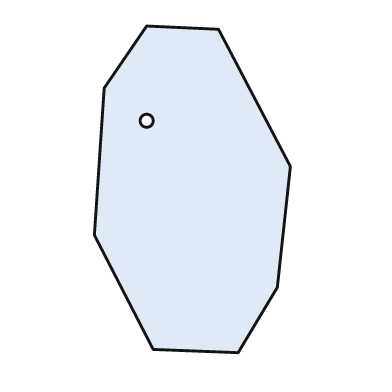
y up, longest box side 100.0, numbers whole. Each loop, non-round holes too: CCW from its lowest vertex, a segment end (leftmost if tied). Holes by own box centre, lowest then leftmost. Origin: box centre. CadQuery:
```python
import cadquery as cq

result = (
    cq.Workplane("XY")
    .moveTo(14.0, -50.0)
    .lineTo(26.0, -30.0)
    .lineTo(30.0, 7.0)
    .lineTo(8.0, 49.0)
    .lineTo(-14.0, 50.0)
    .lineTo(-27.0, 31.0)
    .lineTo(-30.0, -14.0)
    .lineTo(-12.0, -49.0)
    .close()
    .moveTo(-14.0, 21.0)
    .circle(2.0)
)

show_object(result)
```